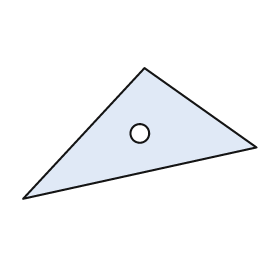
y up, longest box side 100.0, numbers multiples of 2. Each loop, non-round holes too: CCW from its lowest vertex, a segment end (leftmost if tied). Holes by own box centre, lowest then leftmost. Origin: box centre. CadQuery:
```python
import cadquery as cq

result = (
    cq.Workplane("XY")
    .moveTo(-50.0, -28.0)
    .lineTo(50.0, -6.0)
    .lineTo(2.0, 28.0)
    .close()
    .moveTo(0.0, 0.0)
    .circle(4.0)
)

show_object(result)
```